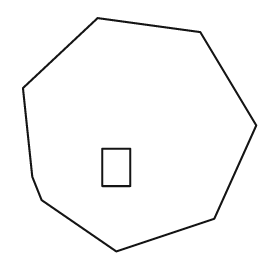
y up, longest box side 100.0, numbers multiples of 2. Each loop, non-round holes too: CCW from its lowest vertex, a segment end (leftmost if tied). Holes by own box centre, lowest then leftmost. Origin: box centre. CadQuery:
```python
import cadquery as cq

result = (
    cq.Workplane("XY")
    .moveTo(-10.0, -50.0)
    .lineTo(32.0, -36.0)
    .lineTo(50.0, 4.0)
    .lineTo(26.0, 44.0)
    .lineTo(-18.0, 50.0)
    .lineTo(-50.0, 20.0)
    .lineTo(-46.0, -18.0)
    .lineTo(-42.0, -28.0)
    .close()
    .moveTo(-16.0, -22.0)
    .lineTo(-4.0, -22.0)
    .lineTo(-4.0, -6.0)
    .lineTo(-16.0, -6.0)
    .close()
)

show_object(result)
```